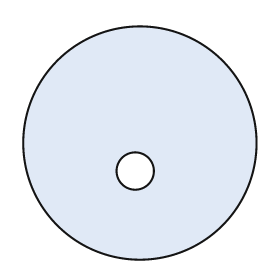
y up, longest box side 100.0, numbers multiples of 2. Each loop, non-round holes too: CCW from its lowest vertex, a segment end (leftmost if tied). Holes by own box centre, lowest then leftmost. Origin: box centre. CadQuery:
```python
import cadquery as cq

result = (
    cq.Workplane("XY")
    .moveTo(0.0, 0.0)
    .circle(50.0)
    .moveTo(-2.0, -12.0)
    .circle(8.0)
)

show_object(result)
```